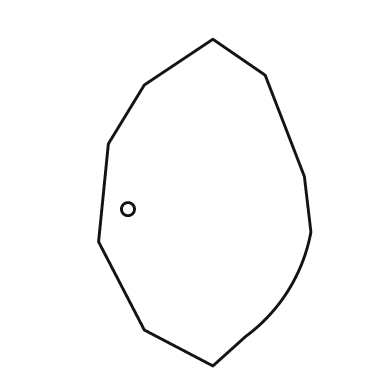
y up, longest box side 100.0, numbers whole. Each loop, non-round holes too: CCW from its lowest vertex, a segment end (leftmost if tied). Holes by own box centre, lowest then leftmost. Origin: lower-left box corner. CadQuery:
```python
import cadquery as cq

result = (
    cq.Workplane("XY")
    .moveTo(35.0, 0.0)
    .lineTo(45.0, 9.0)
    .threePointArc((58.0, 23.0), (65.0, 41.0))
    .lineTo(63.0, 58.0)
    .lineTo(51.0, 89.0)
    .lineTo(35.0, 100.0)
    .lineTo(14.0, 86.0)
    .lineTo(3.0, 68.0)
    .lineTo(0.0, 38.0)
    .lineTo(14.0, 11.0)
    .close()
    .moveTo(9.0, 48.0)
    .circle(2.0)
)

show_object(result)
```